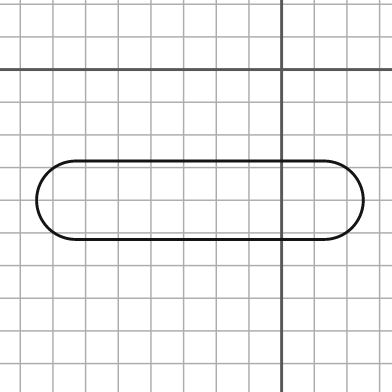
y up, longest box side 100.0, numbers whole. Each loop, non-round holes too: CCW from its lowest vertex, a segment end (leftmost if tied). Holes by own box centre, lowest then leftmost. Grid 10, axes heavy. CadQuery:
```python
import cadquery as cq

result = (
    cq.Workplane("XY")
    .moveTo(-63.0, -52.0)
    .lineTo(13.0, -52.0)
    .threePointArc((25.0, -40.0), (13.0, -28.0))
    .lineTo(-63.0, -28.0)
    .threePointArc((-75.0, -40.0), (-63.0, -52.0))
    .close()
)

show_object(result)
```